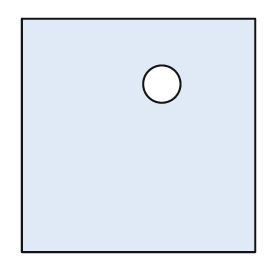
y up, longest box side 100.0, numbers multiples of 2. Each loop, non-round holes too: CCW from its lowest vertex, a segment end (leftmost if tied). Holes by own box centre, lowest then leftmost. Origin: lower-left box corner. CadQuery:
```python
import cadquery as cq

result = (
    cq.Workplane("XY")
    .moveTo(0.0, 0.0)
    .lineTo(100.0, 0.0)
    .lineTo(100.0, 100.0)
    .lineTo(0.0, 100.0)
    .close()
    .moveTo(60.0, 72.0)
    .circle(8.0)
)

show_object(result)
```